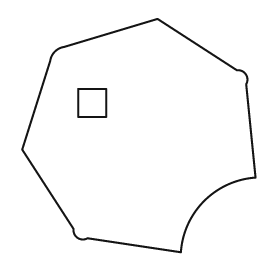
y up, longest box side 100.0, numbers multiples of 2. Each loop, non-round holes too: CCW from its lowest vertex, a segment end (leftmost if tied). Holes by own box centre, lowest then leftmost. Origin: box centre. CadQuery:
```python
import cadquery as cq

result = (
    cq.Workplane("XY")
    .moveTo(18.0, -50.0)
    .threePointArc((28.0, -28.0), (50.0, -18.0))
    .lineTo(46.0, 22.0)
    .threePointArc((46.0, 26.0), (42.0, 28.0))
    .lineTo(8.0, 50.0)
    .lineTo(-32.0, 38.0)
    .threePointArc((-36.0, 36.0), (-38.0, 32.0))
    .lineTo(-50.0, -6.0)
    .lineTo(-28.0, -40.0)
    .threePointArc((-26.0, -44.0), (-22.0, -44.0))
    .close()
    .moveTo(-26.0, 8.0)
    .lineTo(-14.0, 8.0)
    .lineTo(-14.0, 20.0)
    .lineTo(-26.0, 20.0)
    .close()
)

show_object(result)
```